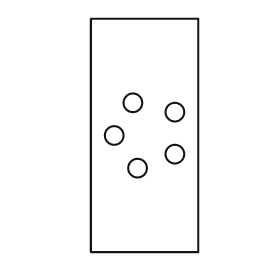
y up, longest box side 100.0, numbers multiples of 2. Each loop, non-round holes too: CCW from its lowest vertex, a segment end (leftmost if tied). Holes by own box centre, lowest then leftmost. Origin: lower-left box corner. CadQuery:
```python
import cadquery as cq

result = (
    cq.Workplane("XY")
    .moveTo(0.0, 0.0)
    .lineTo(46.0, 0.0)
    .lineTo(46.0, 100.0)
    .lineTo(0.0, 100.0)
    .close()
    .moveTo(20.0, 36.0)
    .circle(4.0)
    .moveTo(36.0, 42.0)
    .circle(4.0)
    .moveTo(10.0, 50.0)
    .circle(4.0)
    .moveTo(36.0, 60.0)
    .circle(4.0)
    .moveTo(18.0, 64.0)
    .circle(4.0)
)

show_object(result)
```